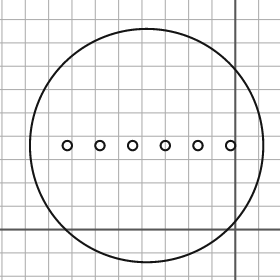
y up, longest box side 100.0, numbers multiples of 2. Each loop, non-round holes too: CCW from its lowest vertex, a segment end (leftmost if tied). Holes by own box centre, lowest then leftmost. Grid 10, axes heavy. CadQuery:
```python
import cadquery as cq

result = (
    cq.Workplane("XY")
    .moveTo(-38.0, 36.0)
    .circle(50.0)
    .moveTo(-72.0, 36.0)
    .circle(2.0)
    .moveTo(-58.0, 36.0)
    .circle(2.0)
    .moveTo(-44.0, 36.0)
    .circle(2.0)
    .moveTo(-30.0, 36.0)
    .circle(2.0)
    .moveTo(-16.0, 36.0)
    .circle(2.0)
    .moveTo(-2.0, 36.0)
    .circle(2.0)
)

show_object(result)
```